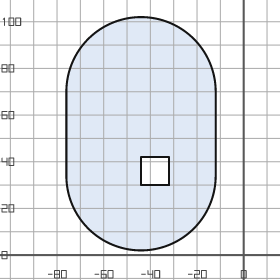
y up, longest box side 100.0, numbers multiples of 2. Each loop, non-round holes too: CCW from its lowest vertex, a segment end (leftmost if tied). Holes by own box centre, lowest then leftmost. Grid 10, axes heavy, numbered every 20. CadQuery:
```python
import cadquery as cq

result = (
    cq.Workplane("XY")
    .moveTo(-76.0, 34.0)
    .threePointArc((-44.0, 2.0), (-12.0, 34.0))
    .lineTo(-12.0, 70.0)
    .threePointArc((-44.0, 102.0), (-76.0, 70.0))
    .close()
    .moveTo(-44.0, 30.0)
    .lineTo(-32.0, 30.0)
    .lineTo(-32.0, 42.0)
    .lineTo(-44.0, 42.0)
    .close()
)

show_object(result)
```